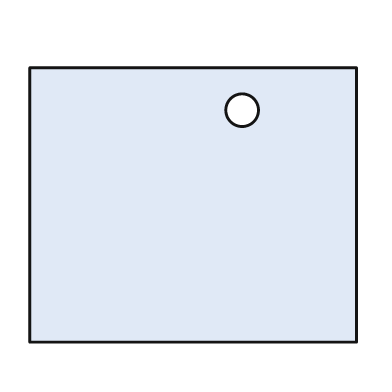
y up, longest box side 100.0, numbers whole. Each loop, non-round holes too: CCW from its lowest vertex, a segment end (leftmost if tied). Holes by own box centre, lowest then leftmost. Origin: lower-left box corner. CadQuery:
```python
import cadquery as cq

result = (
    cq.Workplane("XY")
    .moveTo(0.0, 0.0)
    .lineTo(100.0, 0.0)
    .lineTo(100.0, 84.0)
    .lineTo(0.0, 84.0)
    .close()
    .moveTo(65.0, 71.0)
    .circle(5.0)
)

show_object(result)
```